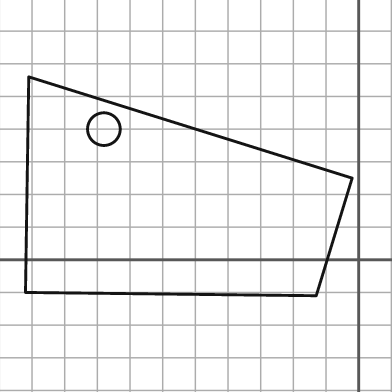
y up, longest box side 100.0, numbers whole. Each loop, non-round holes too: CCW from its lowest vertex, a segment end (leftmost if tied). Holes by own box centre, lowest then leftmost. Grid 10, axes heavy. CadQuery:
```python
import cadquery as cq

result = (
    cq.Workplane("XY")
    .moveTo(-13.0, -11.0)
    .lineTo(-2.0, 25.0)
    .lineTo(-101.0, 56.0)
    .lineTo(-102.0, -10.0)
    .close()
    .moveTo(-78.0, 40.0)
    .circle(5.0)
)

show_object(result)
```